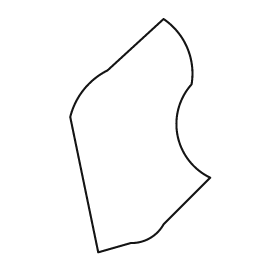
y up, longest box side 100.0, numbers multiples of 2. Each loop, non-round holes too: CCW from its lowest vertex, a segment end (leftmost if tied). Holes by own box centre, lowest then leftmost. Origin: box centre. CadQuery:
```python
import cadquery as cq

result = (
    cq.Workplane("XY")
    .moveTo(-18.0, -50.0)
    .lineTo(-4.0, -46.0)
    .threePointArc((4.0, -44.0), (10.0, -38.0))
    .lineTo(30.0, -18.0)
    .threePointArc((16.0, 0.0), (22.0, 22.0))
    .threePointArc((20.0, 38.0), (10.0, 50.0))
    .lineTo(-14.0, 28.0)
    .threePointArc((-24.0, 20.0), (-30.0, 8.0))
    .close()
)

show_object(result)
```